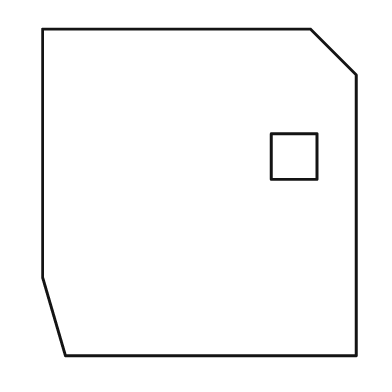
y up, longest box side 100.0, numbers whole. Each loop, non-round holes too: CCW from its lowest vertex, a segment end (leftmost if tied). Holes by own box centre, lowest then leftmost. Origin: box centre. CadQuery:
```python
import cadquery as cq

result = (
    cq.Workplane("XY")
    .moveTo(-41.0, -50.0)
    .lineTo(48.0, -50.0)
    .lineTo(48.0, 36.0)
    .lineTo(34.0, 50.0)
    .lineTo(-48.0, 50.0)
    .lineTo(-48.0, -26.0)
    .close()
    .moveTo(22.0, 4.0)
    .lineTo(36.0, 4.0)
    .lineTo(36.0, 18.0)
    .lineTo(22.0, 18.0)
    .close()
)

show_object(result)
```